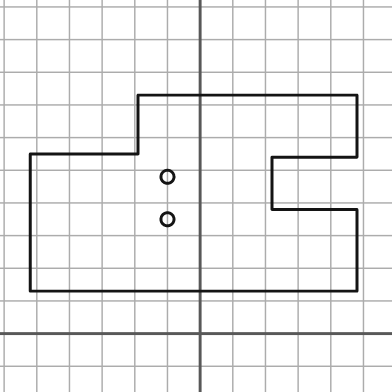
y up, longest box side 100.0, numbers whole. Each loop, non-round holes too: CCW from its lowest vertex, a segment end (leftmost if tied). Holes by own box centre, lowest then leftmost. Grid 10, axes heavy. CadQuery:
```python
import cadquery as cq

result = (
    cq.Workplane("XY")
    .moveTo(-52.0, 13.0)
    .lineTo(48.0, 13.0)
    .lineTo(48.0, 38.0)
    .lineTo(22.0, 38.0)
    .lineTo(22.0, 54.0)
    .lineTo(48.0, 54.0)
    .lineTo(48.0, 73.0)
    .lineTo(-19.0, 73.0)
    .lineTo(-19.0, 55.0)
    .lineTo(-52.0, 55.0)
    .close()
    .moveTo(-10.0, 35.0)
    .circle(2.0)
    .moveTo(-10.0, 48.0)
    .circle(2.0)
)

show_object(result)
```